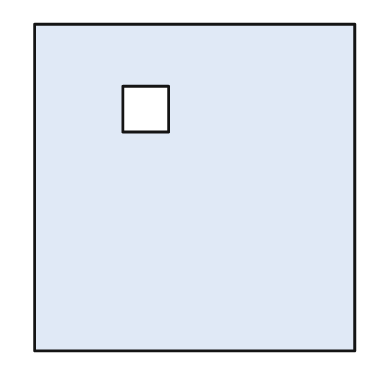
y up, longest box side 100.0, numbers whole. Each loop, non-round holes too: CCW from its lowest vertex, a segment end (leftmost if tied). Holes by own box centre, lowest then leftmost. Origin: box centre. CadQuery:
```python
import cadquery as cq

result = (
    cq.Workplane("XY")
    .moveTo(-49.0, -50.0)
    .lineTo(49.0, -50.0)
    .lineTo(49.0, 50.0)
    .lineTo(-49.0, 50.0)
    .close()
    .moveTo(-22.0, 17.0)
    .lineTo(-8.0, 17.0)
    .lineTo(-8.0, 31.0)
    .lineTo(-22.0, 31.0)
    .close()
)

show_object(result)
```